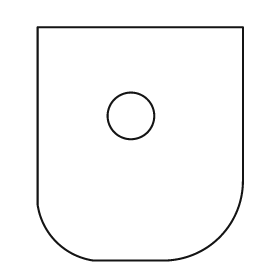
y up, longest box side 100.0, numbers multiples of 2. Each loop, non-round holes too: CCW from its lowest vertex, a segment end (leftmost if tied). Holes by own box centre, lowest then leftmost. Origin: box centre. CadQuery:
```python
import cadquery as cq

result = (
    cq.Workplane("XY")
    .moveTo(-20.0, -50.0)
    .lineTo(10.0, -50.0)
    .threePointArc((34.0, -40.0), (44.0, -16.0))
    .lineTo(44.0, 50.0)
    .lineTo(-44.0, 50.0)
    .lineTo(-44.0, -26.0)
    .threePointArc((-36.0, -42.0), (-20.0, -50.0))
    .close()
    .moveTo(-4.0, 12.0)
    .circle(10.0)
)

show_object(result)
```